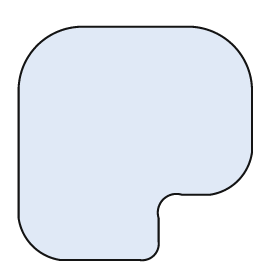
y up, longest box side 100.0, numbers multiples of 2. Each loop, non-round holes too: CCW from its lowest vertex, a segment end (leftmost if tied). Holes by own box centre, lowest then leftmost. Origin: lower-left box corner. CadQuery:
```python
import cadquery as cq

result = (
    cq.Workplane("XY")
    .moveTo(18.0, 0.0)
    .lineTo(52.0, 0.0)
    .threePointArc((58.0, 2.0), (60.0, 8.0))
    .lineTo(60.0, 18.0)
    .threePointArc((62.0, 26.0), (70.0, 28.0))
    .lineTo(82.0, 28.0)
    .threePointArc((94.0, 34.0), (100.0, 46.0))
    .lineTo(100.0, 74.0)
    .threePointArc((92.0, 92.0), (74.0, 100.0))
    .lineTo(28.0, 100.0)
    .threePointArc((8.0, 92.0), (0.0, 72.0))
    .lineTo(0.0, 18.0)
    .threePointArc((6.0, 6.0), (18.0, 0.0))
    .close()
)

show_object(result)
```